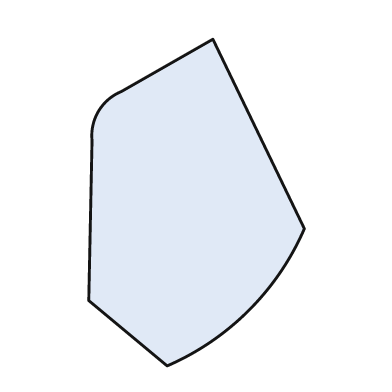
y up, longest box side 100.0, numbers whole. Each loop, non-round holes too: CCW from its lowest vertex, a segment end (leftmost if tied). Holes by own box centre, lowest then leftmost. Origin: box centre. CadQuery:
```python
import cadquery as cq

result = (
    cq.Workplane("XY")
    .moveTo(-9.0, -50.0)
    .threePointArc((16.0, -33.0), (33.0, -8.0))
    .lineTo(5.0, 50.0)
    .lineTo(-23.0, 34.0)
    .threePointArc((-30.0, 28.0), (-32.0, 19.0))
    .lineTo(-33.0, -30.0)
    .close()
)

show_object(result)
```